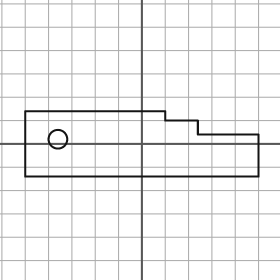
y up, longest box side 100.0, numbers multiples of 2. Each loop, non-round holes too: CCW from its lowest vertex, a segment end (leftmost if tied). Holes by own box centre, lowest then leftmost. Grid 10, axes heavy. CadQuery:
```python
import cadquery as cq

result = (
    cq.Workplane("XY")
    .moveTo(-50.0, -14.0)
    .lineTo(50.0, -14.0)
    .lineTo(50.0, 4.0)
    .lineTo(24.0, 4.0)
    .lineTo(24.0, 10.0)
    .lineTo(10.0, 10.0)
    .lineTo(10.0, 14.0)
    .lineTo(-50.0, 14.0)
    .close()
    .moveTo(-36.0, 2.0)
    .circle(4.0)
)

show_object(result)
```